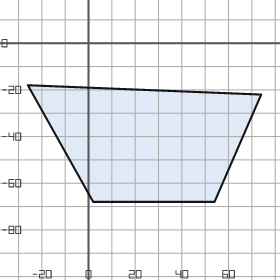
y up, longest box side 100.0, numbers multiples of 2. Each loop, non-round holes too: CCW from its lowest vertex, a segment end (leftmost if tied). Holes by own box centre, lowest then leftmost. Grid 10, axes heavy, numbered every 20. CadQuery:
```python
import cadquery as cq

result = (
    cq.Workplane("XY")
    .moveTo(2.0, -68.0)
    .lineTo(54.0, -68.0)
    .lineTo(74.0, -22.0)
    .lineTo(-26.0, -18.0)
    .close()
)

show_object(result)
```